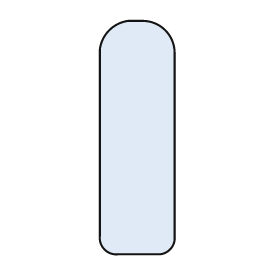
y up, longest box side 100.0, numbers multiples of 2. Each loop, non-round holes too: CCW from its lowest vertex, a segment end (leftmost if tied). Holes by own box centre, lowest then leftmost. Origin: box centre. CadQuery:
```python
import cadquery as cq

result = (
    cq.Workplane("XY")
    .moveTo(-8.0, -50.0)
    .lineTo(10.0, -50.0)
    .threePointArc((14.0, -48.0), (16.0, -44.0))
    .lineTo(16.0, 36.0)
    .threePointArc((12.0, 46.0), (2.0, 50.0))
    .lineTo(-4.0, 50.0)
    .threePointArc((-12.0, 46.0), (-16.0, 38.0))
    .lineTo(-16.0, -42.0)
    .threePointArc((-14.0, -48.0), (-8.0, -50.0))
    .close()
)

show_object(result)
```